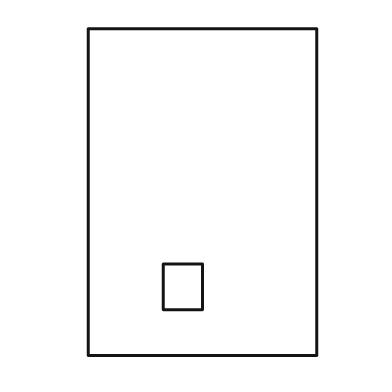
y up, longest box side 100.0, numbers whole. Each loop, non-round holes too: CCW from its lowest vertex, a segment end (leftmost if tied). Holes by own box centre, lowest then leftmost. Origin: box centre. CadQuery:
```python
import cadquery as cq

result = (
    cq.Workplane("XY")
    .moveTo(-35.0, -50.0)
    .lineTo(35.0, -50.0)
    .lineTo(35.0, 50.0)
    .lineTo(-35.0, 50.0)
    .close()
    .moveTo(-12.0, -36.0)
    .lineTo(0.0, -36.0)
    .lineTo(0.0, -22.0)
    .lineTo(-12.0, -22.0)
    .close()
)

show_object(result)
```